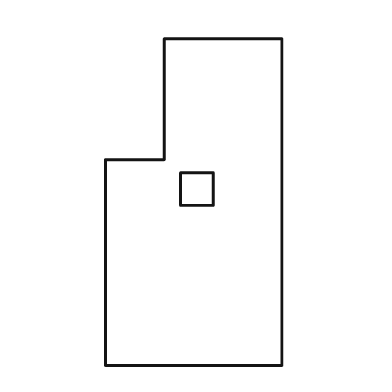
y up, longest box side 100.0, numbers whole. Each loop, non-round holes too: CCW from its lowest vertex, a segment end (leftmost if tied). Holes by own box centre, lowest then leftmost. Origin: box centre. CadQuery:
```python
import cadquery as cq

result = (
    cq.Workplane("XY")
    .moveTo(-27.0, -50.0)
    .lineTo(27.0, -50.0)
    .lineTo(27.0, 50.0)
    .lineTo(-9.0, 50.0)
    .lineTo(-9.0, 13.0)
    .lineTo(-27.0, 13.0)
    .close()
    .moveTo(-4.0, -1.0)
    .lineTo(6.0, -1.0)
    .lineTo(6.0, 9.0)
    .lineTo(-4.0, 9.0)
    .close()
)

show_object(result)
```